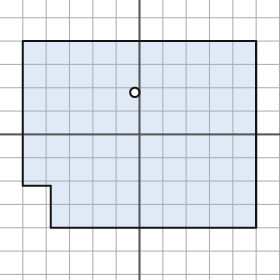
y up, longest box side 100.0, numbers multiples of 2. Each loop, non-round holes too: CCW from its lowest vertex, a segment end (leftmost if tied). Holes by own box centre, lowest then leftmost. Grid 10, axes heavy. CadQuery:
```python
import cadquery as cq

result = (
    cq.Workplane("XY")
    .moveTo(-38.0, -40.0)
    .lineTo(50.0, -40.0)
    .lineTo(50.0, 40.0)
    .lineTo(-50.0, 40.0)
    .lineTo(-50.0, -22.0)
    .lineTo(-38.0, -22.0)
    .close()
    .moveTo(-2.0, 18.0)
    .circle(2.0)
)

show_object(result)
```